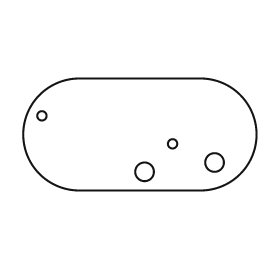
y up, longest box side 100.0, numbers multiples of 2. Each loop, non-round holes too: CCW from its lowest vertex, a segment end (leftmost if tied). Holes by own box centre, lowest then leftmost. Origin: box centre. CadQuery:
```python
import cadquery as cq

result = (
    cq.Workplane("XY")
    .moveTo(-26.0, -24.0)
    .lineTo(26.0, -24.0)
    .threePointArc((50.0, 0.0), (26.0, 24.0))
    .lineTo(-26.0, 24.0)
    .threePointArc((-50.0, 0.0), (-26.0, -24.0))
    .close()
    .moveTo(2.0, -16.0)
    .circle(4.0)
    .moveTo(32.0, -12.0)
    .circle(4.0)
    .moveTo(14.0, -4.0)
    .circle(2.0)
    .moveTo(-42.0, 8.0)
    .circle(2.0)
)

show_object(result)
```